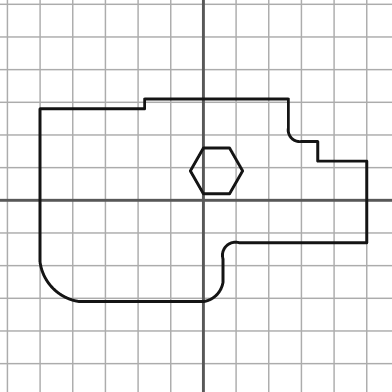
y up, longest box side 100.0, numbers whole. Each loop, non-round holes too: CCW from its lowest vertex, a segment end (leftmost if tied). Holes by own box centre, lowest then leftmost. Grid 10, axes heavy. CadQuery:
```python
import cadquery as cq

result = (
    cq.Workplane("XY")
    .moveTo(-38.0, -31.0)
    .lineTo(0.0, -31.0)
    .threePointArc((4.0, -29.0), (6.0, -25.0))
    .lineTo(6.0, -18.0)
    .threePointArc((7.0, -14.0), (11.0, -13.0))
    .lineTo(50.0, -13.0)
    .lineTo(50.0, 12.0)
    .lineTo(35.0, 12.0)
    .lineTo(35.0, 18.0)
    .lineTo(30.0, 18.0)
    .threePointArc((27.0, 19.0), (26.0, 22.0))
    .lineTo(26.0, 31.0)
    .lineTo(-18.0, 31.0)
    .lineTo(-18.0, 28.0)
    .lineTo(-50.0, 28.0)
    .lineTo(-50.0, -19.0)
    .threePointArc((-46.0, -27.0), (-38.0, -31.0))
    .close()
    .moveTo(0.0, 2.0)
    .lineTo(8.0, 2.0)
    .lineTo(12.0, 9.0)
    .lineTo(8.0, 16.0)
    .lineTo(0.0, 16.0)
    .lineTo(-4.0, 9.0)
    .close()
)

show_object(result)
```